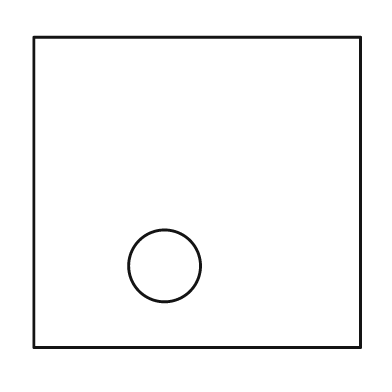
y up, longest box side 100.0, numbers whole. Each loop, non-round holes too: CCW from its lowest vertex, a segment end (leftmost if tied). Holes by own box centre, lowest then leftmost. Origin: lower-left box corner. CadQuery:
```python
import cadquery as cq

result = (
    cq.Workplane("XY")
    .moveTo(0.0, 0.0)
    .lineTo(100.0, 0.0)
    .lineTo(100.0, 95.0)
    .lineTo(0.0, 95.0)
    .close()
    .moveTo(40.0, 25.0)
    .circle(11.0)
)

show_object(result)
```